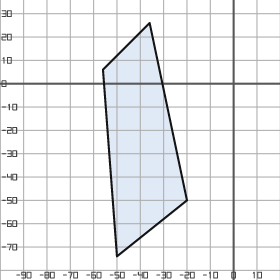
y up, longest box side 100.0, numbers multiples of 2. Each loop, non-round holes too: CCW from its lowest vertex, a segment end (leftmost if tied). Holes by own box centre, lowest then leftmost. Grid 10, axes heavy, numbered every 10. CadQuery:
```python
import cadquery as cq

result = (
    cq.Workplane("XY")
    .moveTo(-50.0, -74.0)
    .lineTo(-20.0, -50.0)
    .lineTo(-36.0, 26.0)
    .lineTo(-56.0, 6.0)
    .close()
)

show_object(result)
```